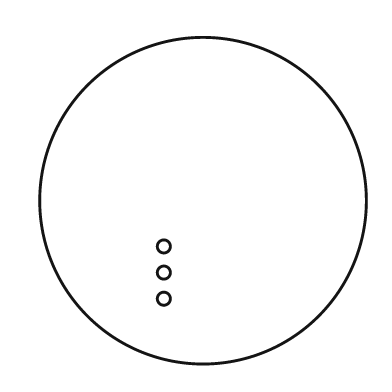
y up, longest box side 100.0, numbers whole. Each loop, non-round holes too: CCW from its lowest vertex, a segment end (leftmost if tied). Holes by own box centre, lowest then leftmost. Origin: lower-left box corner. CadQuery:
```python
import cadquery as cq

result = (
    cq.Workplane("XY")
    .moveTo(50.0, 50.0)
    .circle(50.0)
    .moveTo(38.0, 20.0)
    .circle(2.0)
    .moveTo(38.0, 28.0)
    .circle(2.0)
    .moveTo(38.0, 36.0)
    .circle(2.0)
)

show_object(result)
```